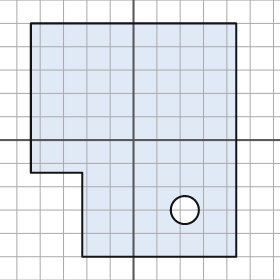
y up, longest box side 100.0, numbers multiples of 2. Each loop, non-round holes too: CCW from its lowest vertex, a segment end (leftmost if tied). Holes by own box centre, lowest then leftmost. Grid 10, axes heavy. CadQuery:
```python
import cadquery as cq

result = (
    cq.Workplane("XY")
    .moveTo(-22.0, -50.0)
    .lineTo(44.0, -50.0)
    .lineTo(44.0, 50.0)
    .lineTo(-44.0, 50.0)
    .lineTo(-44.0, -14.0)
    .lineTo(-22.0, -14.0)
    .close()
    .moveTo(22.0, -30.0)
    .circle(6.0)
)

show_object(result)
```